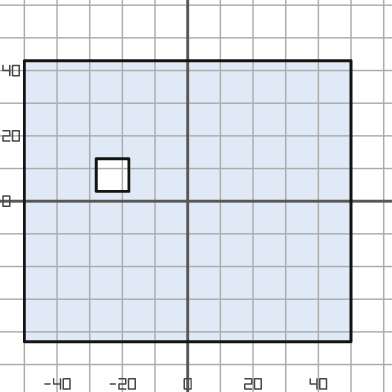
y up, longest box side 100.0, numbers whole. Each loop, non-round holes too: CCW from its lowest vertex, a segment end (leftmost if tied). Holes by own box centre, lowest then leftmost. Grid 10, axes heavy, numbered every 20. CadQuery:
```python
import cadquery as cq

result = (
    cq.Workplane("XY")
    .moveTo(-50.0, -43.0)
    .lineTo(50.0, -43.0)
    .lineTo(50.0, 43.0)
    .lineTo(-50.0, 43.0)
    .close()
    .moveTo(-28.0, 3.0)
    .lineTo(-18.0, 3.0)
    .lineTo(-18.0, 13.0)
    .lineTo(-28.0, 13.0)
    .close()
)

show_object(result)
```